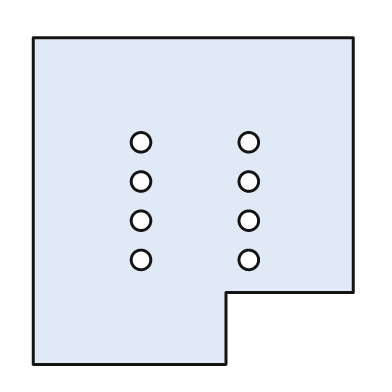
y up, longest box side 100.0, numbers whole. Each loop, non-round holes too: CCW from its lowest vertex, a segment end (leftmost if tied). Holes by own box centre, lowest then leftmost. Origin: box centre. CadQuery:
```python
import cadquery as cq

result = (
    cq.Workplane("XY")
    .moveTo(-49.0, -50.0)
    .lineTo(10.0, -50.0)
    .lineTo(10.0, -28.0)
    .lineTo(49.0, -28.0)
    .lineTo(49.0, 50.0)
    .lineTo(-49.0, 50.0)
    .close()
    .moveTo(-16.0, -18.0)
    .circle(3.0)
    .moveTo(17.0, -18.0)
    .circle(3.0)
    .moveTo(-16.0, -6.0)
    .circle(3.0)
    .moveTo(17.0, -6.0)
    .circle(3.0)
    .moveTo(-16.0, 6.0)
    .circle(3.0)
    .moveTo(17.0, 6.0)
    .circle(3.0)
    .moveTo(-16.0, 18.0)
    .circle(3.0)
    .moveTo(17.0, 18.0)
    .circle(3.0)
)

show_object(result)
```